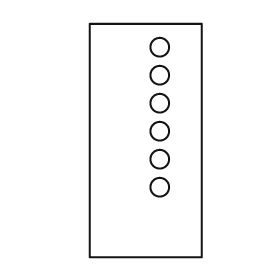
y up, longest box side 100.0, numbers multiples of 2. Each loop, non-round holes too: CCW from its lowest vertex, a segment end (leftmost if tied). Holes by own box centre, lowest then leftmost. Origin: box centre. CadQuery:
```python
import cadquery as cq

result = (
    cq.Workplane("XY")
    .moveTo(-24.0, -50.0)
    .lineTo(24.0, -50.0)
    .lineTo(24.0, 50.0)
    .lineTo(-24.0, 50.0)
    .close()
    .moveTo(6.0, -20.0)
    .circle(4.0)
    .moveTo(6.0, -8.0)
    .circle(4.0)
    .moveTo(6.0, 4.0)
    .circle(4.0)
    .moveTo(6.0, 16.0)
    .circle(4.0)
    .moveTo(6.0, 28.0)
    .circle(4.0)
    .moveTo(6.0, 40.0)
    .circle(4.0)
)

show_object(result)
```